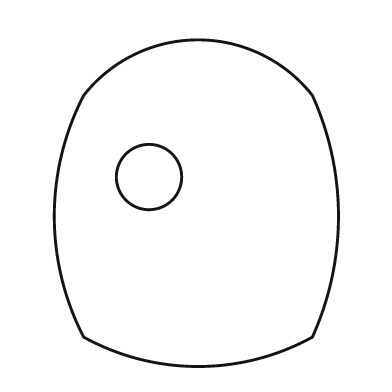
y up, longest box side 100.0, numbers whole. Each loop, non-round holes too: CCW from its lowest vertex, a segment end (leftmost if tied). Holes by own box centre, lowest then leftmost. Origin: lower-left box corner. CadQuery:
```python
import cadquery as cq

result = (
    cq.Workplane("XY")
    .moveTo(9.0, 9.0)
    .threePointArc((44.0, 0.0), (79.0, 9.0))
    .threePointArc((87.0, 46.0), (79.0, 83.0))
    .threePointArc((44.0, 100.0), (9.0, 83.0))
    .threePointArc((0.0, 46.0), (9.0, 9.0))
    .close()
    .moveTo(29.0, 58.0)
    .circle(10.0)
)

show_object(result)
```